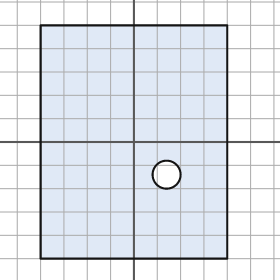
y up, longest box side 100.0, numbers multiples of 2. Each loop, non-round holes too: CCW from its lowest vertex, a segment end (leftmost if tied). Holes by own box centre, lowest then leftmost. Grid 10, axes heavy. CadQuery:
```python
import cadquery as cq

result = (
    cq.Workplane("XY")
    .moveTo(-40.0, -50.0)
    .lineTo(40.0, -50.0)
    .lineTo(40.0, 50.0)
    .lineTo(-40.0, 50.0)
    .close()
    .moveTo(14.0, -14.0)
    .circle(6.0)
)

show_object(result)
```